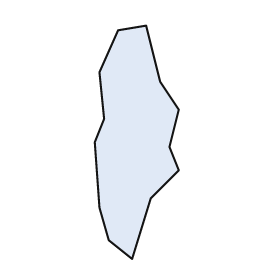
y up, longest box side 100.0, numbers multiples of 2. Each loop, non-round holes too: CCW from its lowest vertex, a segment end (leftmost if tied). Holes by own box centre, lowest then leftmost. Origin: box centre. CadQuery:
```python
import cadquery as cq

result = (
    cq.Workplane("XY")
    .moveTo(-2.0, -50.0)
    .lineTo(6.0, -24.0)
    .lineTo(18.0, -12.0)
    .lineTo(14.0, -2.0)
    .lineTo(18.0, 14.0)
    .lineTo(10.0, 26.0)
    .lineTo(4.0, 50.0)
    .lineTo(-8.0, 48.0)
    .lineTo(-16.0, 30.0)
    .lineTo(-14.0, 10.0)
    .lineTo(-18.0, 0.0)
    .lineTo(-16.0, -28.0)
    .lineTo(-12.0, -42.0)
    .close()
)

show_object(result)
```